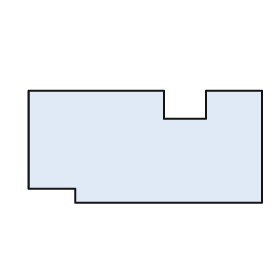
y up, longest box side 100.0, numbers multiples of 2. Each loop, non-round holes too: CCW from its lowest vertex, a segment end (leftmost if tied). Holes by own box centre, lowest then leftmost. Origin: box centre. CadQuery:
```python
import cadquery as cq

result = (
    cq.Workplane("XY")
    .moveTo(-30.0, -24.0)
    .lineTo(50.0, -24.0)
    .lineTo(50.0, 24.0)
    .lineTo(26.0, 24.0)
    .lineTo(26.0, 12.0)
    .lineTo(8.0, 12.0)
    .lineTo(8.0, 24.0)
    .lineTo(-50.0, 24.0)
    .lineTo(-50.0, -18.0)
    .lineTo(-30.0, -18.0)
    .close()
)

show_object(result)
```